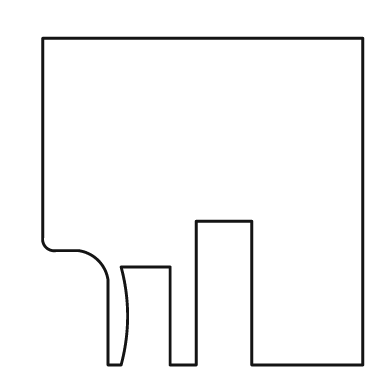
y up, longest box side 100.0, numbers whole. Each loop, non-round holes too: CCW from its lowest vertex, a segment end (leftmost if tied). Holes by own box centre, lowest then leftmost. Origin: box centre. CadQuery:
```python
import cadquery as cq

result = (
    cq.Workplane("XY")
    .moveTo(-29.0, -50.0)
    .lineTo(-25.0, -50.0)
    .threePointArc((-23.0, -35.0), (-25.0, -20.0))
    .lineTo(-10.0, -20.0)
    .lineTo(-10.0, -50.0)
    .lineTo(-2.0, -50.0)
    .lineTo(-2.0, -6.0)
    .lineTo(15.0, -6.0)
    .lineTo(15.0, -50.0)
    .lineTo(49.0, -50.0)
    .lineTo(49.0, 50.0)
    .lineTo(-49.0, 50.0)
    .lineTo(-49.0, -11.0)
    .threePointArc((-48.0, -14.0), (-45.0, -15.0))
    .lineTo(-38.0, -15.0)
    .threePointArc((-32.0, -18.0), (-29.0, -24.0))
    .close()
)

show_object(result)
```